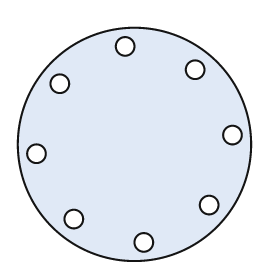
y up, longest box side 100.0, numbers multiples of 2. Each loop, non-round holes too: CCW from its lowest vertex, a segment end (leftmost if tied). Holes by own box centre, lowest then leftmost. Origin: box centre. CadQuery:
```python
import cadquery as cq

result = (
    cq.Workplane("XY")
    .moveTo(0.0, 0.0)
    .circle(50.0)
    .moveTo(4.0, -42.0)
    .circle(4.0)
    .moveTo(-26.0, -32.0)
    .circle(4.0)
    .moveTo(32.0, -26.0)
    .circle(4.0)
    .moveTo(-42.0, -4.0)
    .circle(4.0)
    .moveTo(42.0, 4.0)
    .circle(4.0)
    .moveTo(-32.0, 26.0)
    .circle(4.0)
    .moveTo(26.0, 32.0)
    .circle(4.0)
    .moveTo(-4.0, 42.0)
    .circle(4.0)
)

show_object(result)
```